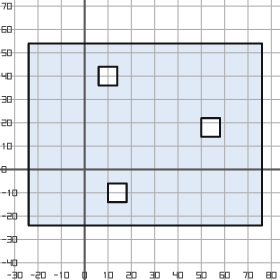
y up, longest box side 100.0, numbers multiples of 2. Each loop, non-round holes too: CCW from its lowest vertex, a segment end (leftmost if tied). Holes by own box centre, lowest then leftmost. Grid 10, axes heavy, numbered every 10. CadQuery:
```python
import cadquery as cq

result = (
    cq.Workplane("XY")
    .moveTo(-24.0, -24.0)
    .lineTo(76.0, -24.0)
    .lineTo(76.0, 54.0)
    .lineTo(-24.0, 54.0)
    .close()
    .moveTo(10.0, -14.0)
    .lineTo(18.0, -14.0)
    .lineTo(18.0, -6.0)
    .lineTo(10.0, -6.0)
    .close()
    .moveTo(50.0, 14.0)
    .lineTo(58.0, 14.0)
    .lineTo(58.0, 22.0)
    .lineTo(50.0, 22.0)
    .close()
    .moveTo(6.0, 36.0)
    .lineTo(14.0, 36.0)
    .lineTo(14.0, 44.0)
    .lineTo(6.0, 44.0)
    .close()
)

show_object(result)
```